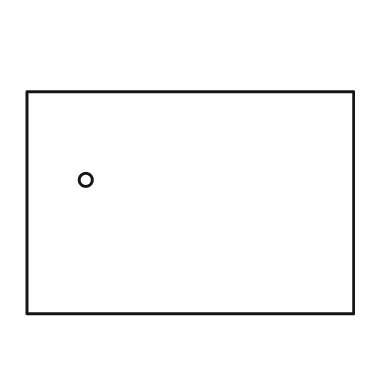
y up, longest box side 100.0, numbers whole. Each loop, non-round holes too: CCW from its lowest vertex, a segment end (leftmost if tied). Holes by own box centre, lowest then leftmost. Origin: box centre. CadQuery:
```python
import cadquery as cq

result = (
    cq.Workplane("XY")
    .moveTo(-50.0, -34.0)
    .lineTo(50.0, -34.0)
    .lineTo(50.0, 34.0)
    .lineTo(-50.0, 34.0)
    .close()
    .moveTo(-32.0, 7.0)
    .circle(2.0)
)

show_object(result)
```